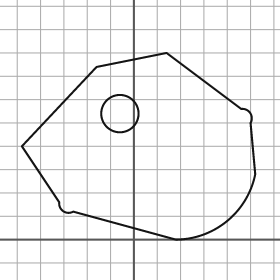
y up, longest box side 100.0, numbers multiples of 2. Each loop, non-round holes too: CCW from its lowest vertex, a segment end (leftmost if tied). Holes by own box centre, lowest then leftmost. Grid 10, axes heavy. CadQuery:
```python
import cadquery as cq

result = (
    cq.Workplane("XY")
    .moveTo(18.0, 0.0)
    .threePointArc((40.0, 8.0), (52.0, 28.0))
    .lineTo(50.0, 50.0)
    .threePointArc((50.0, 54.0), (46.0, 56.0))
    .lineTo(14.0, 80.0)
    .lineTo(-16.0, 74.0)
    .lineTo(-48.0, 40.0)
    .lineTo(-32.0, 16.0)
    .threePointArc((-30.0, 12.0), (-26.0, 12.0))
    .close()
    .moveTo(-6.0, 54.0)
    .circle(8.0)
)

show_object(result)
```